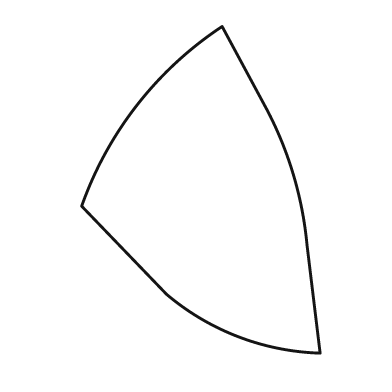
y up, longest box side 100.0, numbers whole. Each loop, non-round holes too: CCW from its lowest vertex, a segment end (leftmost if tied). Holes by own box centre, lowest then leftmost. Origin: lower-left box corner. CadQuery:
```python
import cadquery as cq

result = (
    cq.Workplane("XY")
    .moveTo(73.0, 0.0)
    .lineTo(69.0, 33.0)
    .threePointArc((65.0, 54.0), (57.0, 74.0))
    .lineTo(43.0, 100.0)
    .threePointArc((17.0, 76.0), (0.0, 45.0))
    .lineTo(26.0, 18.0)
    .threePointArc((48.0, 5.0), (73.0, 0.0))
    .close()
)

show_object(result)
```